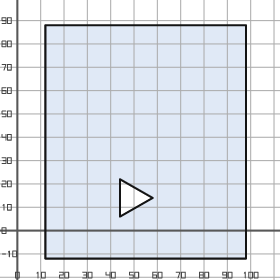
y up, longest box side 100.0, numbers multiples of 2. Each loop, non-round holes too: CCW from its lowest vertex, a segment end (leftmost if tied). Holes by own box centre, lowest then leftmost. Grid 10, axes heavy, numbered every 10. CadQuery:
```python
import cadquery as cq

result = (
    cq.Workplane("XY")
    .moveTo(12.0, -12.0)
    .lineTo(98.0, -12.0)
    .lineTo(98.0, 88.0)
    .lineTo(12.0, 88.0)
    .close()
    .moveTo(44.0, 6.0)
    .lineTo(58.0, 14.0)
    .lineTo(44.0, 22.0)
    .close()
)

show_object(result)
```